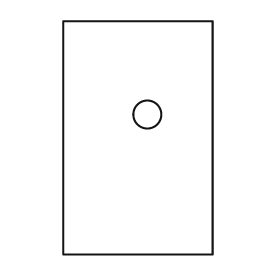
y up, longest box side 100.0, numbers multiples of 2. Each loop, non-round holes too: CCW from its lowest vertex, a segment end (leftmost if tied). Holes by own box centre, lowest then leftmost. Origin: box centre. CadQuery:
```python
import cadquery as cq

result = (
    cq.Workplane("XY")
    .moveTo(-32.0, -50.0)
    .lineTo(32.0, -50.0)
    .lineTo(32.0, 50.0)
    .lineTo(-32.0, 50.0)
    .close()
    .moveTo(4.0, 10.0)
    .circle(6.0)
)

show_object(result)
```